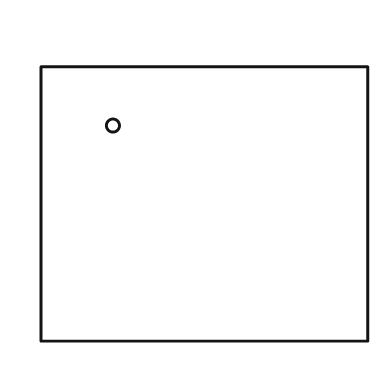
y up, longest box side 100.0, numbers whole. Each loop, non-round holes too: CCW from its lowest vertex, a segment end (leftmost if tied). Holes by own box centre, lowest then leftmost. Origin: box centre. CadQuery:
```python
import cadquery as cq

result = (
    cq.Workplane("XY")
    .moveTo(-50.0, -42.0)
    .lineTo(50.0, -42.0)
    .lineTo(50.0, 42.0)
    .lineTo(-50.0, 42.0)
    .close()
    .moveTo(-28.0, 24.0)
    .circle(2.0)
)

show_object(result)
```